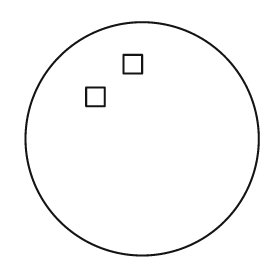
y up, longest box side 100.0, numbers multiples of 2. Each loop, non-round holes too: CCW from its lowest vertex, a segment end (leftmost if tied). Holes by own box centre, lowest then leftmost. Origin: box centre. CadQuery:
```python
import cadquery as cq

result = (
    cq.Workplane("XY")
    .moveTo(0.0, 0.0)
    .circle(50.0)
    .moveTo(-24.0, 14.0)
    .lineTo(-16.0, 14.0)
    .lineTo(-16.0, 22.0)
    .lineTo(-24.0, 22.0)
    .close()
    .moveTo(-8.0, 28.0)
    .lineTo(0.0, 28.0)
    .lineTo(0.0, 36.0)
    .lineTo(-8.0, 36.0)
    .close()
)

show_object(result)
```